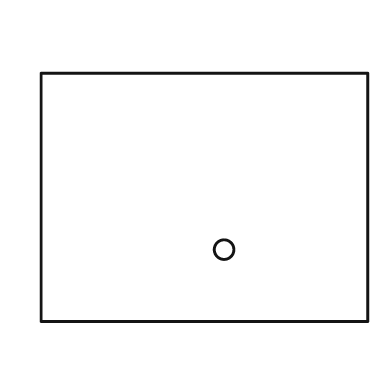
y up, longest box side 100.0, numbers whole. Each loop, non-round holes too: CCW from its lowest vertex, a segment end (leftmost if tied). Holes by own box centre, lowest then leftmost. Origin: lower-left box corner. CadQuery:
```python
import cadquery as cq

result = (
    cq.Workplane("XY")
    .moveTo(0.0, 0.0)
    .lineTo(100.0, 0.0)
    .lineTo(100.0, 76.0)
    .lineTo(0.0, 76.0)
    .close()
    .moveTo(56.0, 22.0)
    .circle(3.0)
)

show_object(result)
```